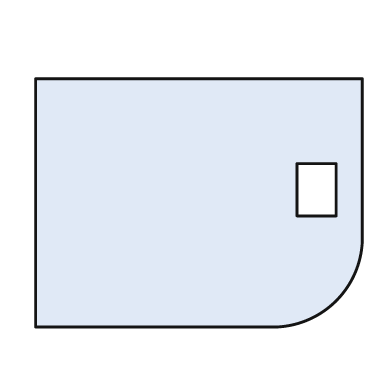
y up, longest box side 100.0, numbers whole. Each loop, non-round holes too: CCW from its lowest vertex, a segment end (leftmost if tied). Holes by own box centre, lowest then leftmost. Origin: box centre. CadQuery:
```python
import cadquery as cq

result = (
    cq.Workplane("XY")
    .moveTo(-50.0, -38.0)
    .lineTo(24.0, -38.0)
    .threePointArc((42.0, -30.0), (50.0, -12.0))
    .lineTo(50.0, 38.0)
    .lineTo(-50.0, 38.0)
    .close()
    .moveTo(30.0, -4.0)
    .lineTo(42.0, -4.0)
    .lineTo(42.0, 12.0)
    .lineTo(30.0, 12.0)
    .close()
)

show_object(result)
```